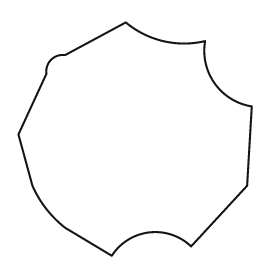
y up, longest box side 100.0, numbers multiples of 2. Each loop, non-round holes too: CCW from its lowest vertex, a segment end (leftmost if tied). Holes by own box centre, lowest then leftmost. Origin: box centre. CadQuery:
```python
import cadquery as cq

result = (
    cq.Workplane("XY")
    .moveTo(-10.0, -50.0)
    .threePointArc((6.0, -40.0), (24.0, -46.0))
    .lineTo(48.0, -20.0)
    .lineTo(50.0, 14.0)
    .threePointArc((34.0, 24.0), (30.0, 42.0))
    .threePointArc((12.0, 42.0), (-4.0, 50.0))
    .lineTo(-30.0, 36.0)
    .threePointArc((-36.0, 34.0), (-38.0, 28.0))
    .lineTo(-50.0, 2.0)
    .lineTo(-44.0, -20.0)
    .threePointArc((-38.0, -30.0), (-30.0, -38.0))
    .close()
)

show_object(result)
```